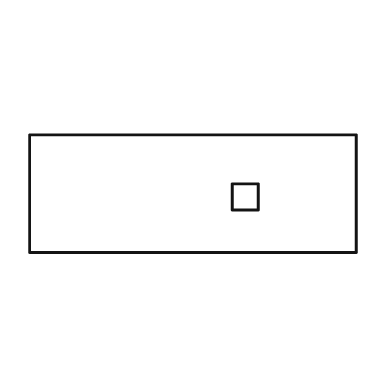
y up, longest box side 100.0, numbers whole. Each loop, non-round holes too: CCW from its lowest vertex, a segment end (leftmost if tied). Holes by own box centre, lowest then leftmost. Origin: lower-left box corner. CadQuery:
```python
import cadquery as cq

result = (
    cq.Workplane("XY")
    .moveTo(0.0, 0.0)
    .lineTo(100.0, 0.0)
    .lineTo(100.0, 36.0)
    .lineTo(0.0, 36.0)
    .close()
    .moveTo(62.0, 13.0)
    .lineTo(70.0, 13.0)
    .lineTo(70.0, 21.0)
    .lineTo(62.0, 21.0)
    .close()
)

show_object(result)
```